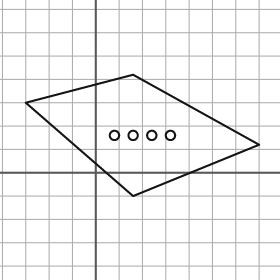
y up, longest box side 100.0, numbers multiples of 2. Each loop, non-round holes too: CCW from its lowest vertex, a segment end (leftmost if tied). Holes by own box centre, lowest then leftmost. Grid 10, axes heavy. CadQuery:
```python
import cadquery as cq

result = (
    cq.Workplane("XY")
    .moveTo(16.0, -10.0)
    .lineTo(70.0, 12.0)
    .lineTo(16.0, 42.0)
    .lineTo(-30.0, 30.0)
    .close()
    .moveTo(8.0, 16.0)
    .circle(2.0)
    .moveTo(16.0, 16.0)
    .circle(2.0)
    .moveTo(24.0, 16.0)
    .circle(2.0)
    .moveTo(32.0, 16.0)
    .circle(2.0)
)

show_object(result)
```